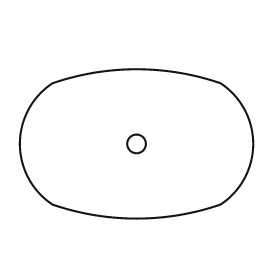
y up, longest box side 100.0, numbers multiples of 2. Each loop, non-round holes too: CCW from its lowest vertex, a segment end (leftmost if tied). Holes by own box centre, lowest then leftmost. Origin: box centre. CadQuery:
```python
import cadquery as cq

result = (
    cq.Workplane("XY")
    .moveTo(-36.0, -26.0)
    .threePointArc((0.0, -32.0), (36.0, -26.0))
    .threePointArc((50.0, 0.0), (36.0, 26.0))
    .threePointArc((0.0, 32.0), (-36.0, 26.0))
    .threePointArc((-50.0, 0.0), (-36.0, -26.0))
    .close()
    .moveTo(0.0, 0.0)
    .circle(4.0)
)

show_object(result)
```